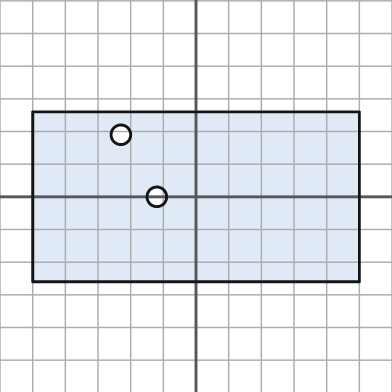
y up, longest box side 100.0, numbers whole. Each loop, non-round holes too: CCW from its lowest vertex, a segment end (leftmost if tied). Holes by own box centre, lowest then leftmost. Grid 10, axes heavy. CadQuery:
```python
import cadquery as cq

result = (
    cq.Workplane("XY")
    .moveTo(-50.0, -26.0)
    .lineTo(50.0, -26.0)
    .lineTo(50.0, 26.0)
    .lineTo(-50.0, 26.0)
    .close()
    .moveTo(-12.0, 0.0)
    .circle(3.0)
    .moveTo(-23.0, 19.0)
    .circle(3.0)
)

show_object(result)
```